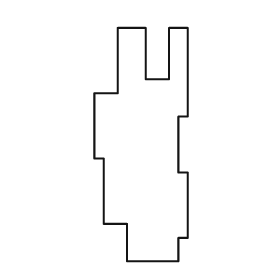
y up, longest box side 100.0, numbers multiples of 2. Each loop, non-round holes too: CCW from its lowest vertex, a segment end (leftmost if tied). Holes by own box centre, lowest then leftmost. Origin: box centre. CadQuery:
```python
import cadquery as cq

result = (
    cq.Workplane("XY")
    .moveTo(-6.0, -50.0)
    .lineTo(16.0, -50.0)
    .lineTo(16.0, -40.0)
    .lineTo(20.0, -40.0)
    .lineTo(20.0, -12.0)
    .lineTo(16.0, -12.0)
    .lineTo(16.0, 12.0)
    .lineTo(20.0, 12.0)
    .lineTo(20.0, 50.0)
    .lineTo(12.0, 50.0)
    .lineTo(12.0, 28.0)
    .lineTo(2.0, 28.0)
    .lineTo(2.0, 50.0)
    .lineTo(-10.0, 50.0)
    .lineTo(-10.0, 22.0)
    .lineTo(-20.0, 22.0)
    .lineTo(-20.0, -6.0)
    .lineTo(-16.0, -6.0)
    .lineTo(-16.0, -34.0)
    .lineTo(-6.0, -34.0)
    .close()
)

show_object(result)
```